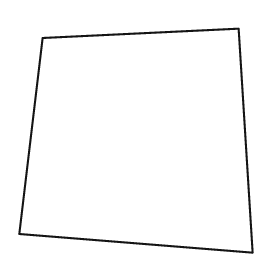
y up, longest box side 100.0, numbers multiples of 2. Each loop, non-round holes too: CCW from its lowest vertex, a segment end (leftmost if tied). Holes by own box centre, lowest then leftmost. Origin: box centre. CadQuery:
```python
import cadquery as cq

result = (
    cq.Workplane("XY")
    .moveTo(50.0, -48.0)
    .lineTo(44.0, 48.0)
    .lineTo(-40.0, 44.0)
    .lineTo(-50.0, -40.0)
    .close()
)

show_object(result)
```